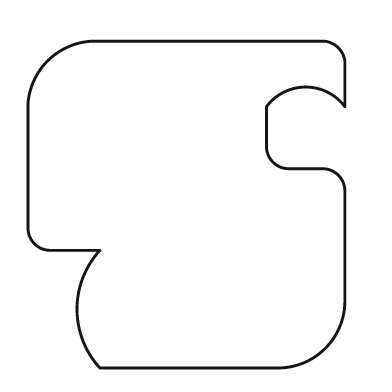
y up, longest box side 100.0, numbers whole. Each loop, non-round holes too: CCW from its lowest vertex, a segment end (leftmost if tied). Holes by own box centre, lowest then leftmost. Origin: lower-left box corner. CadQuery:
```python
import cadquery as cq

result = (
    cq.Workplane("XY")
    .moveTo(22.0, 0.0)
    .lineTo(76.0, 0.0)
    .threePointArc((91.0, 6.0), (97.0, 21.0))
    .lineTo(97.0, 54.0)
    .threePointArc((95.0, 59.0), (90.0, 61.0))
    .lineTo(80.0, 61.0)
    .threePointArc((75.0, 63.0), (73.0, 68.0))
    .lineTo(73.0, 80.0)
    .threePointArc((85.0, 86.0), (97.0, 80.0))
    .lineTo(97.0, 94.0)
    .threePointArc((95.0, 98.0), (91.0, 100.0))
    .lineTo(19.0, 100.0)
    .threePointArc((6.0, 94.0), (0.0, 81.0))
    .lineTo(0.0, 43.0)
    .threePointArc((2.0, 38.0), (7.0, 36.0))
    .lineTo(22.0, 36.0)
    .threePointArc((15.0, 18.0), (22.0, 0.0))
    .close()
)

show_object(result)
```